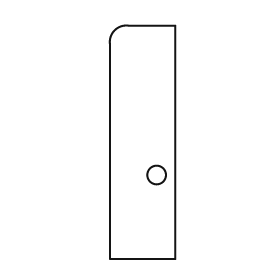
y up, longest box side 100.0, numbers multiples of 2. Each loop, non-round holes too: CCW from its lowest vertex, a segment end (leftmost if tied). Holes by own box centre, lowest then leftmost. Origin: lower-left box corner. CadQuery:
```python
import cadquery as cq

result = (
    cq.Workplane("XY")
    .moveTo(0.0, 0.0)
    .lineTo(28.0, 0.0)
    .lineTo(28.0, 100.0)
    .lineTo(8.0, 100.0)
    .threePointArc((2.0, 98.0), (0.0, 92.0))
    .close()
    .moveTo(20.0, 36.0)
    .circle(4.0)
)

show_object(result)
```